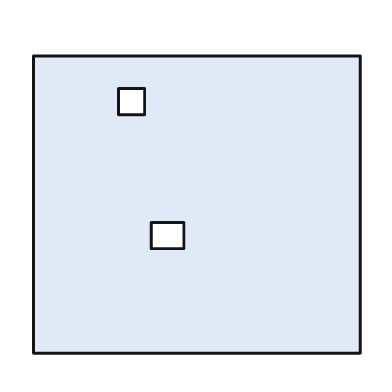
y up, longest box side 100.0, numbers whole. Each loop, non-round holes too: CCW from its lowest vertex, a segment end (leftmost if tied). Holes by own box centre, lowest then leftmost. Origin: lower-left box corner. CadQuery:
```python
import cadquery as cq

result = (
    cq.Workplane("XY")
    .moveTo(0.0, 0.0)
    .lineTo(100.0, 0.0)
    .lineTo(100.0, 91.0)
    .lineTo(0.0, 91.0)
    .close()
    .moveTo(36.0, 32.0)
    .lineTo(46.0, 32.0)
    .lineTo(46.0, 40.0)
    .lineTo(36.0, 40.0)
    .close()
    .moveTo(26.0, 73.0)
    .lineTo(34.0, 73.0)
    .lineTo(34.0, 81.0)
    .lineTo(26.0, 81.0)
    .close()
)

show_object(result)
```